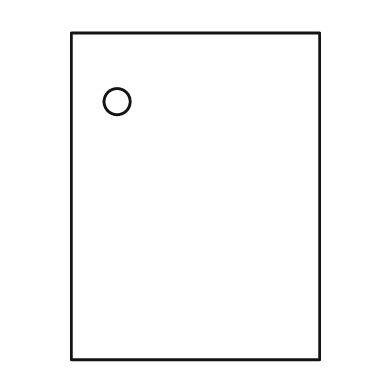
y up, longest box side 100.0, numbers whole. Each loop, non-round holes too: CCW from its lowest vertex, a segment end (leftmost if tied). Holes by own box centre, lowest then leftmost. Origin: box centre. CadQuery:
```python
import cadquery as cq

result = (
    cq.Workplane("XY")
    .moveTo(-38.0, -50.0)
    .lineTo(38.0, -50.0)
    .lineTo(38.0, 50.0)
    .lineTo(-38.0, 50.0)
    .close()
    .moveTo(-24.0, 29.0)
    .circle(4.0)
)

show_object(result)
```